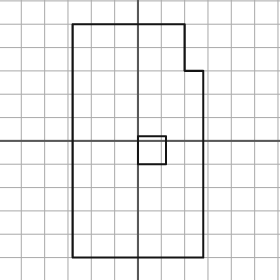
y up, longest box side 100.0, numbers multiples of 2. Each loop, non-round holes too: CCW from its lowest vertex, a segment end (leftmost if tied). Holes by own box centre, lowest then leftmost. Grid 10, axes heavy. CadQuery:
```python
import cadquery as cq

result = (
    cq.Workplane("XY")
    .moveTo(-28.0, -50.0)
    .lineTo(28.0, -50.0)
    .lineTo(28.0, 30.0)
    .lineTo(20.0, 30.0)
    .lineTo(20.0, 50.0)
    .lineTo(-28.0, 50.0)
    .close()
    .moveTo(0.0, -10.0)
    .lineTo(12.0, -10.0)
    .lineTo(12.0, 2.0)
    .lineTo(0.0, 2.0)
    .close()
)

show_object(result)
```